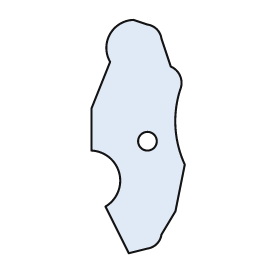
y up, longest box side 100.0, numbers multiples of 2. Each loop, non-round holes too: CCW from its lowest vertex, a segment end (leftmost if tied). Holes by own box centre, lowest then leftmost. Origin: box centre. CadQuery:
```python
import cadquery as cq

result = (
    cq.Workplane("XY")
    .moveTo(-4.0, -50.0)
    .lineTo(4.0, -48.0)
    .threePointArc((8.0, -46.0), (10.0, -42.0))
    .lineTo(16.0, -32.0)
    .lineTo(20.0, -12.0)
    .threePointArc((16.0, 4.0), (18.0, 20.0))
    .threePointArc((18.0, 26.0), (14.0, 30.0))
    .lineTo(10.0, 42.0)
    .threePointArc((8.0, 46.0), (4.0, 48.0))
    .lineTo(-2.0, 50.0)
    .threePointArc((-12.0, 44.0), (-12.0, 32.0))
    .lineTo(-20.0, 12.0)
    .lineTo(-20.0, -6.0)
    .threePointArc((-8.0, -16.0), (-14.0, -30.0))
    .close()
    .moveTo(4.0, -2.0)
    .circle(4.0)
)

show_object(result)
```